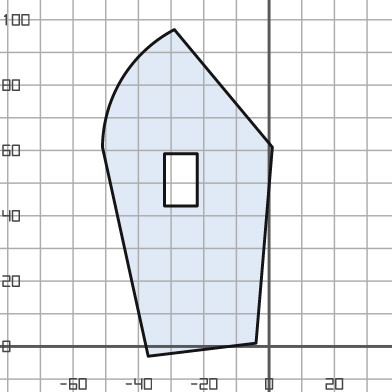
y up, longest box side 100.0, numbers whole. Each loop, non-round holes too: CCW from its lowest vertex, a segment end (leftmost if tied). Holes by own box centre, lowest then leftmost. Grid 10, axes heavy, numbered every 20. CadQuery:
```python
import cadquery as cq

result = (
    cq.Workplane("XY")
    .moveTo(-37.0, -3.0)
    .lineTo(-4.0, 1.0)
    .lineTo(1.0, 61.0)
    .lineTo(-29.0, 97.0)
    .threePointArc((-45.0, 82.0), (-51.0, 61.0))
    .close()
    .moveTo(-32.0, 43.0)
    .lineTo(-22.0, 43.0)
    .lineTo(-22.0, 59.0)
    .lineTo(-32.0, 59.0)
    .close()
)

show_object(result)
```